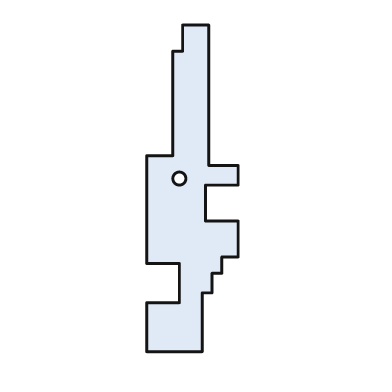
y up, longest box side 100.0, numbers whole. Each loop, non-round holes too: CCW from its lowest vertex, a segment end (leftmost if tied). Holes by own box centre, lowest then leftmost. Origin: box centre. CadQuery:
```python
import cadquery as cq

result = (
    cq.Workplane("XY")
    .moveTo(-14.0, -50.0)
    .lineTo(3.0, -50.0)
    .lineTo(3.0, -32.0)
    .lineTo(6.0, -32.0)
    .lineTo(6.0, -26.0)
    .lineTo(9.0, -26.0)
    .lineTo(9.0, -21.0)
    .lineTo(14.0, -21.0)
    .lineTo(14.0, -10.0)
    .lineTo(4.0, -10.0)
    .lineTo(4.0, 1.0)
    .lineTo(14.0, 1.0)
    .lineTo(14.0, 7.0)
    .lineTo(5.0, 7.0)
    .lineTo(5.0, 50.0)
    .lineTo(-3.0, 50.0)
    .lineTo(-3.0, 42.0)
    .lineTo(-6.0, 42.0)
    .lineTo(-6.0, 10.0)
    .lineTo(-14.0, 10.0)
    .lineTo(-14.0, -23.0)
    .lineTo(-4.0, -23.0)
    .lineTo(-4.0, -35.0)
    .lineTo(-14.0, -35.0)
    .close()
    .moveTo(-4.0, 3.0)
    .circle(2.0)
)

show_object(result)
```